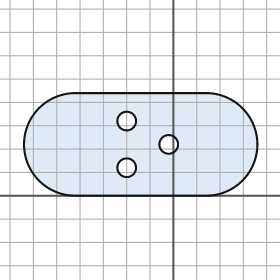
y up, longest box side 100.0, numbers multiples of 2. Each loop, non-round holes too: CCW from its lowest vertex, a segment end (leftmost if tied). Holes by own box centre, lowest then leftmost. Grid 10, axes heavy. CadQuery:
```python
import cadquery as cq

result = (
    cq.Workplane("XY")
    .moveTo(-42.0, 0.0)
    .lineTo(14.0, 0.0)
    .threePointArc((36.0, 22.0), (14.0, 44.0))
    .lineTo(-42.0, 44.0)
    .threePointArc((-64.0, 22.0), (-42.0, 0.0))
    .close()
    .moveTo(-20.0, 12.0)
    .circle(4.0)
    .moveTo(-2.0, 22.0)
    .circle(4.0)
    .moveTo(-20.0, 32.0)
    .circle(4.0)
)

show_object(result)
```